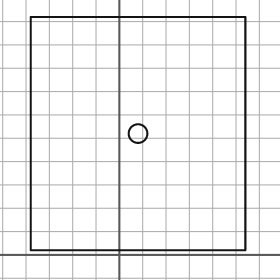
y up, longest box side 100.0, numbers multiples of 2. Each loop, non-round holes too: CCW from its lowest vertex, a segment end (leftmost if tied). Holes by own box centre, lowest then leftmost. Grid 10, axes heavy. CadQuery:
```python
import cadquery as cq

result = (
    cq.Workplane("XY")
    .moveTo(-38.0, 2.0)
    .lineTo(54.0, 2.0)
    .lineTo(54.0, 102.0)
    .lineTo(-38.0, 102.0)
    .close()
    .moveTo(8.0, 52.0)
    .circle(4.0)
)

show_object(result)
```